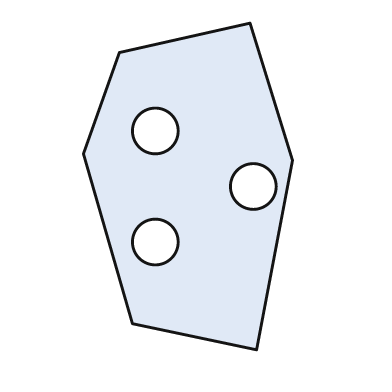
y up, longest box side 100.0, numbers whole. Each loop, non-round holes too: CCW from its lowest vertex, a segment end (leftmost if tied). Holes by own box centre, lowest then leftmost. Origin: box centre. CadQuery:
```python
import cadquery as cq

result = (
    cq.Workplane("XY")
    .moveTo(21.0, -50.0)
    .lineTo(32.0, 8.0)
    .lineTo(19.0, 50.0)
    .lineTo(-21.0, 41.0)
    .lineTo(-32.0, 10.0)
    .lineTo(-17.0, -42.0)
    .close()
    .moveTo(-10.0, -17.0)
    .circle(7.0)
    .moveTo(20.0, 0.0)
    .circle(7.0)
    .moveTo(-10.0, 17.0)
    .circle(7.0)
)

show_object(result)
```